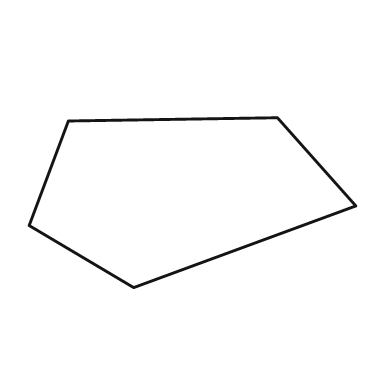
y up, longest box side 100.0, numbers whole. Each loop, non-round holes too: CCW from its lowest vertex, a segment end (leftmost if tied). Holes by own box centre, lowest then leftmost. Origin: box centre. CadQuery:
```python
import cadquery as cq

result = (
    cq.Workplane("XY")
    .moveTo(-18.0, -26.0)
    .lineTo(50.0, -1.0)
    .lineTo(26.0, 26.0)
    .lineTo(-38.0, 25.0)
    .lineTo(-50.0, -7.0)
    .close()
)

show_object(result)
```